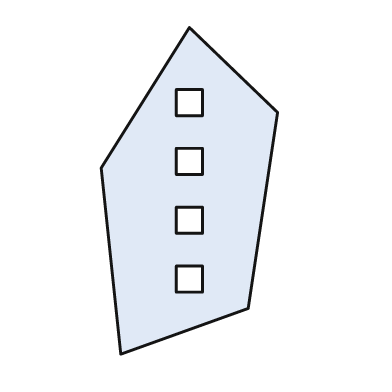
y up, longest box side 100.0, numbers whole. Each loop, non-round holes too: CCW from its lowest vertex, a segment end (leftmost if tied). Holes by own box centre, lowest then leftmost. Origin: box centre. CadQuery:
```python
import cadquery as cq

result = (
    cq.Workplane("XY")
    .moveTo(-21.0, -50.0)
    .lineTo(18.0, -36.0)
    .lineTo(27.0, 24.0)
    .lineTo(0.0, 50.0)
    .lineTo(-27.0, 7.0)
    .close()
    .moveTo(-4.0, -31.0)
    .lineTo(4.0, -31.0)
    .lineTo(4.0, -23.0)
    .lineTo(-4.0, -23.0)
    .close()
    .moveTo(-4.0, -13.0)
    .lineTo(4.0, -13.0)
    .lineTo(4.0, -5.0)
    .lineTo(-4.0, -5.0)
    .close()
    .moveTo(-4.0, 5.0)
    .lineTo(4.0, 5.0)
    .lineTo(4.0, 13.0)
    .lineTo(-4.0, 13.0)
    .close()
    .moveTo(-4.0, 23.0)
    .lineTo(4.0, 23.0)
    .lineTo(4.0, 31.0)
    .lineTo(-4.0, 31.0)
    .close()
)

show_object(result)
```